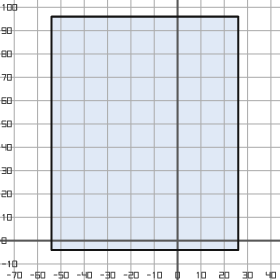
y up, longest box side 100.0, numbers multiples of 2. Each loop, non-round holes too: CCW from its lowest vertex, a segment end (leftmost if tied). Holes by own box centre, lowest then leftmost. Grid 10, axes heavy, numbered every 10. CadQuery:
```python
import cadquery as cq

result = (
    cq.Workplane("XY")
    .moveTo(-54.0, -4.0)
    .lineTo(26.0, -4.0)
    .lineTo(26.0, 96.0)
    .lineTo(-54.0, 96.0)
    .close()
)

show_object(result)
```